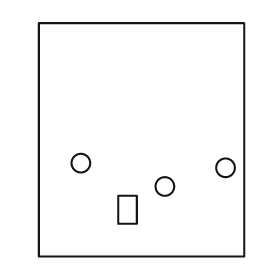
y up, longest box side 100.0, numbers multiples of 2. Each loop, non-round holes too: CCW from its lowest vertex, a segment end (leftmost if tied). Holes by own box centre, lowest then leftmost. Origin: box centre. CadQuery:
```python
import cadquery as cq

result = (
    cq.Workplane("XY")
    .moveTo(-44.0, -50.0)
    .lineTo(44.0, -50.0)
    .lineTo(44.0, 50.0)
    .lineTo(-44.0, 50.0)
    .close()
    .moveTo(-10.0, -36.0)
    .lineTo(-2.0, -36.0)
    .lineTo(-2.0, -24.0)
    .lineTo(-10.0, -24.0)
    .close()
    .moveTo(10.0, -20.0)
    .circle(4.0)
    .moveTo(36.0, -12.0)
    .circle(4.0)
    .moveTo(-26.0, -10.0)
    .circle(4.0)
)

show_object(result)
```